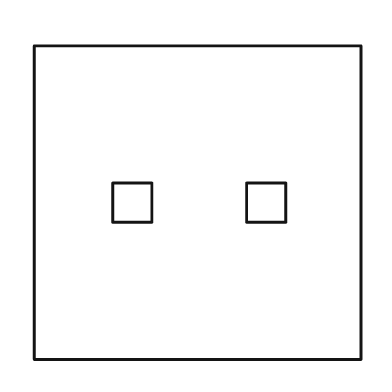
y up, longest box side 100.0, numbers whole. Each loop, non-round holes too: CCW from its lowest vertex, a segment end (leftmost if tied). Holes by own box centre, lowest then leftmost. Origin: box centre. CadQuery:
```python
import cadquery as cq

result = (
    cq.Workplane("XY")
    .moveTo(-50.0, -48.0)
    .lineTo(50.0, -48.0)
    .lineTo(50.0, 48.0)
    .lineTo(-50.0, 48.0)
    .close()
    .moveTo(-26.0, -6.0)
    .lineTo(-14.0, -6.0)
    .lineTo(-14.0, 6.0)
    .lineTo(-26.0, 6.0)
    .close()
    .moveTo(15.0, -6.0)
    .lineTo(27.0, -6.0)
    .lineTo(27.0, 6.0)
    .lineTo(15.0, 6.0)
    .close()
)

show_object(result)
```